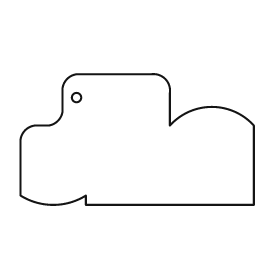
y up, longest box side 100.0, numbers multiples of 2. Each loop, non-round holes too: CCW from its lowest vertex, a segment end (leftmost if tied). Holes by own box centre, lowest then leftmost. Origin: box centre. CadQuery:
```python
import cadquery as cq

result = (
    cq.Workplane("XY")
    .moveTo(-22.0, -28.0)
    .lineTo(50.0, -28.0)
    .lineTo(50.0, 6.0)
    .threePointArc((32.0, 14.0), (14.0, 6.0))
    .lineTo(14.0, 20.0)
    .threePointArc((12.0, 26.0), (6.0, 28.0))
    .lineTo(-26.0, 28.0)
    .threePointArc((-30.0, 26.0), (-32.0, 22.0))
    .lineTo(-32.0, 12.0)
    .threePointArc((-34.0, 8.0), (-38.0, 6.0))
    .lineTo(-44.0, 6.0)
    .threePointArc((-48.0, 4.0), (-50.0, 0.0))
    .lineTo(-50.0, -24.0)
    .threePointArc((-36.0, -28.0), (-22.0, -24.0))
    .close()
    .moveTo(-26.0, 18.0)
    .circle(2.0)
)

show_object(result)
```